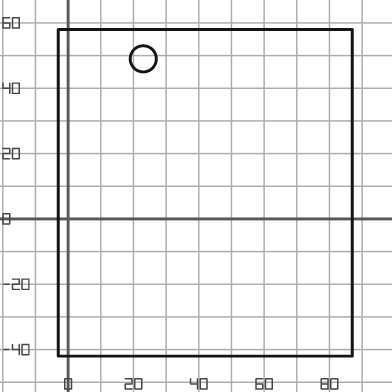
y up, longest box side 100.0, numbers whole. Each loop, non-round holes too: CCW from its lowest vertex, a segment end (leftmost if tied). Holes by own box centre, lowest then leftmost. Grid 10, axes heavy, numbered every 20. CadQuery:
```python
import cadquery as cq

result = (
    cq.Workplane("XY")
    .moveTo(-3.0, -42.0)
    .lineTo(87.0, -42.0)
    .lineTo(87.0, 58.0)
    .lineTo(-3.0, 58.0)
    .close()
    .moveTo(23.0, 49.0)
    .circle(4.0)
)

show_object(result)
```